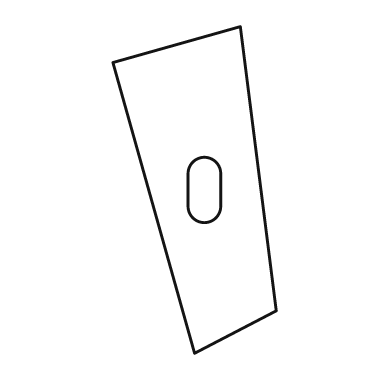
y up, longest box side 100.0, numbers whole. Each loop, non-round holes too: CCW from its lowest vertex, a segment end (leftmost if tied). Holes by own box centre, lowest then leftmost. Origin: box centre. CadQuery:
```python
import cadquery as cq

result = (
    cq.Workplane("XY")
    .moveTo(0.0, -50.0)
    .lineTo(25.0, -37.0)
    .lineTo(14.0, 50.0)
    .lineTo(-25.0, 39.0)
    .close()
    .moveTo(-2.0, -5.0)
    .threePointArc((3.0, -10.0), (8.0, -5.0))
    .lineTo(8.0, 5.0)
    .threePointArc((3.0, 10.0), (-2.0, 5.0))
    .close()
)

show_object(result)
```